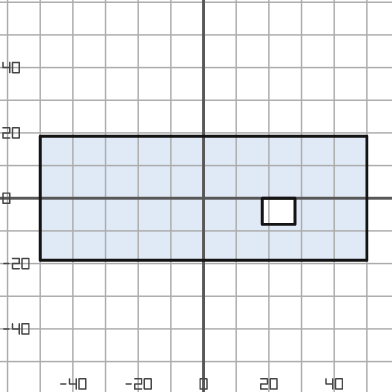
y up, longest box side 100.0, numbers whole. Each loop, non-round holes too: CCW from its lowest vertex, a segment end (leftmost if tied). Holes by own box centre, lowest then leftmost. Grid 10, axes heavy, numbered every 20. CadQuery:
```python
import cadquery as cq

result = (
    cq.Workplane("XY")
    .moveTo(-50.0, -19.0)
    .lineTo(50.0, -19.0)
    .lineTo(50.0, 19.0)
    .lineTo(-50.0, 19.0)
    .close()
    .moveTo(18.0, -8.0)
    .lineTo(28.0, -8.0)
    .lineTo(28.0, 0.0)
    .lineTo(18.0, 0.0)
    .close()
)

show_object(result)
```